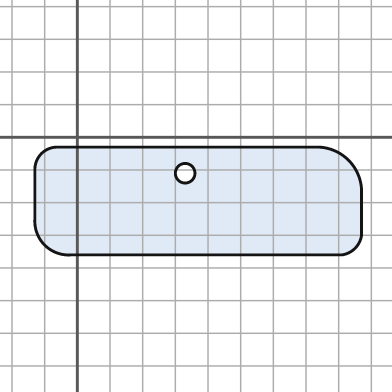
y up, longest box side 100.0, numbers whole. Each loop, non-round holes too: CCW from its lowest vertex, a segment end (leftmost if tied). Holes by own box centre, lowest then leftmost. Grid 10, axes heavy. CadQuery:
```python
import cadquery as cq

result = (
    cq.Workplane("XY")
    .moveTo(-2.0, -36.0)
    .lineTo(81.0, -36.0)
    .threePointArc((85.0, -34.0), (87.0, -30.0))
    .lineTo(87.0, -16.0)
    .threePointArc((83.0, -7.0), (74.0, -3.0))
    .lineTo(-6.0, -3.0)
    .threePointArc((-11.0, -5.0), (-13.0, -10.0))
    .lineTo(-13.0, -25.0)
    .threePointArc((-10.0, -33.0), (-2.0, -36.0))
    .close()
    .moveTo(33.0, -11.0)
    .circle(3.0)
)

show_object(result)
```